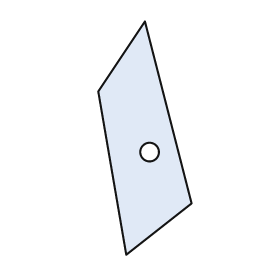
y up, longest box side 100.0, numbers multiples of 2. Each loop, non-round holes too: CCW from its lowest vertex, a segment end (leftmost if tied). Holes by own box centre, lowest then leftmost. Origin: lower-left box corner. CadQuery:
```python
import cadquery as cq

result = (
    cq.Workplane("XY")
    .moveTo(12.0, 0.0)
    .lineTo(40.0, 22.0)
    .lineTo(20.0, 100.0)
    .lineTo(0.0, 70.0)
    .close()
    .moveTo(22.0, 44.0)
    .circle(4.0)
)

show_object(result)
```